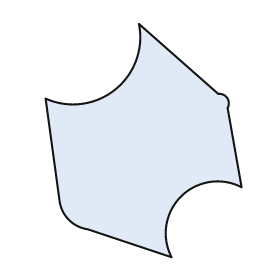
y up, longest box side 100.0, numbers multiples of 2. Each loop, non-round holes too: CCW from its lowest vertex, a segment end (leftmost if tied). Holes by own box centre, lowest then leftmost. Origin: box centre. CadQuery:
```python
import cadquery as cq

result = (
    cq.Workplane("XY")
    .moveTo(12.0, -50.0)
    .threePointArc((16.0, -24.0), (42.0, -20.0))
    .lineTo(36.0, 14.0)
    .threePointArc((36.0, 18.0), (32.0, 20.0))
    .lineTo(-2.0, 50.0)
    .threePointArc((-12.0, 22.0), (-42.0, 18.0))
    .lineTo(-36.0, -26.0)
    .threePointArc((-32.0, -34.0), (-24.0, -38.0))
    .close()
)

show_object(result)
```